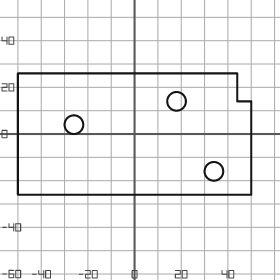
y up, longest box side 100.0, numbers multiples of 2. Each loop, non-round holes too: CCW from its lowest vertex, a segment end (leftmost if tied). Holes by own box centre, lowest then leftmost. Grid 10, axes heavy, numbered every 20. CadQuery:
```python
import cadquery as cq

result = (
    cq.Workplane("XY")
    .moveTo(-50.0, -26.0)
    .lineTo(50.0, -26.0)
    .lineTo(50.0, 14.0)
    .lineTo(44.0, 14.0)
    .lineTo(44.0, 26.0)
    .lineTo(-50.0, 26.0)
    .close()
    .moveTo(34.0, -16.0)
    .circle(4.0)
    .moveTo(-26.0, 4.0)
    .circle(4.0)
    .moveTo(18.0, 14.0)
    .circle(4.0)
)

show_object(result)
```